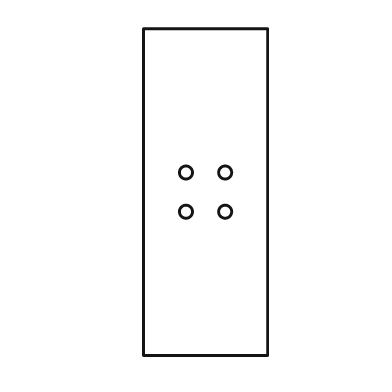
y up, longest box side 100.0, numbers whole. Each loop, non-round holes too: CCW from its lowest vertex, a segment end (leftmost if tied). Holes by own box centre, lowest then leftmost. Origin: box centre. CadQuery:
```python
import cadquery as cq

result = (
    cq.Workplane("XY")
    .moveTo(-19.0, -50.0)
    .lineTo(19.0, -50.0)
    .lineTo(19.0, 50.0)
    .lineTo(-19.0, 50.0)
    .close()
    .moveTo(-6.0, -6.0)
    .circle(2.0)
    .moveTo(6.0, -6.0)
    .circle(2.0)
    .moveTo(-6.0, 6.0)
    .circle(2.0)
    .moveTo(6.0, 6.0)
    .circle(2.0)
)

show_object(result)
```